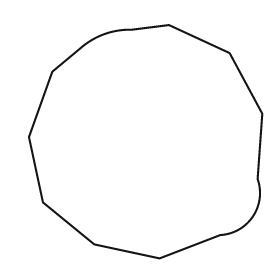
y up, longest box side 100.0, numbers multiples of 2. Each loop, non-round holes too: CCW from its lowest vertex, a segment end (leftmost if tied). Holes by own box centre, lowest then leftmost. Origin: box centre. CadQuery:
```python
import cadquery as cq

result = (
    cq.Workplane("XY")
    .moveTo(6.0, -50.0)
    .lineTo(32.0, -40.0)
    .threePointArc((46.0, -32.0), (48.0, -16.0))
    .lineTo(50.0, 12.0)
    .lineTo(36.0, 38.0)
    .lineTo(10.0, 50.0)
    .lineTo(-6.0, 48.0)
    .threePointArc((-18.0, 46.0), (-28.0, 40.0))
    .lineTo(-40.0, 30.0)
    .lineTo(-50.0, 2.0)
    .lineTo(-44.0, -26.0)
    .lineTo(-22.0, -44.0)
    .close()
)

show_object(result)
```